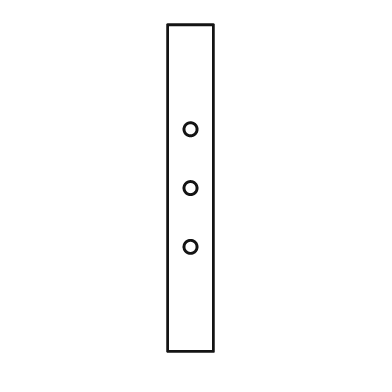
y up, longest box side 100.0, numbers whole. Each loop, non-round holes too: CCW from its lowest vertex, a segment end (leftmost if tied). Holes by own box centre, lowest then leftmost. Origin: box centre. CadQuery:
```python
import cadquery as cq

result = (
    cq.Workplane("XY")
    .moveTo(-7.0, -50.0)
    .lineTo(7.0, -50.0)
    .lineTo(7.0, 50.0)
    .lineTo(-7.0, 50.0)
    .close()
    .moveTo(0.0, -18.0)
    .circle(2.0)
    .moveTo(0.0, 0.0)
    .circle(2.0)
    .moveTo(0.0, 18.0)
    .circle(2.0)
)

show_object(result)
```